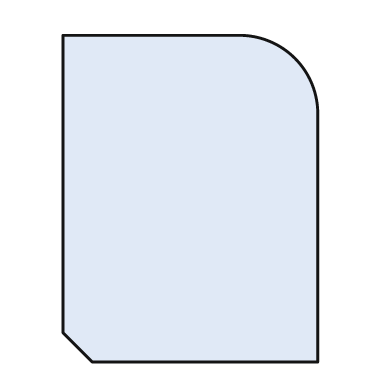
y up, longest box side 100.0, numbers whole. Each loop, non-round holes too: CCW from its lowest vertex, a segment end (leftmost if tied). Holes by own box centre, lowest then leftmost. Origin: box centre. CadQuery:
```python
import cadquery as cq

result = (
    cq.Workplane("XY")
    .moveTo(-30.0, -50.0)
    .lineTo(39.0, -50.0)
    .lineTo(39.0, 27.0)
    .threePointArc((32.0, 43.0), (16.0, 50.0))
    .lineTo(-39.0, 50.0)
    .lineTo(-39.0, -41.0)
    .close()
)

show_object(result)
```